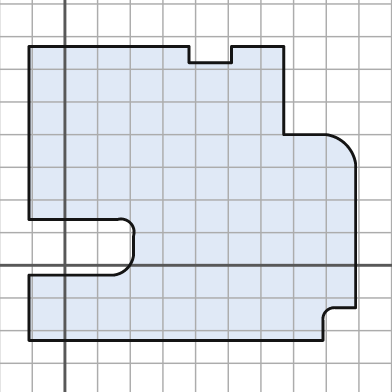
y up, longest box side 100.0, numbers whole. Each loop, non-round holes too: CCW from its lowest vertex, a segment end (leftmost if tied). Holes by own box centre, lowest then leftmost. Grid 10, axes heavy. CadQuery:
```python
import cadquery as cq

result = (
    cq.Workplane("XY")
    .moveTo(-11.0, -23.0)
    .lineTo(79.0, -23.0)
    .lineTo(79.0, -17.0)
    .threePointArc((80.0, -14.0), (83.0, -13.0))
    .lineTo(89.0, -13.0)
    .lineTo(89.0, 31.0)
    .threePointArc((86.0, 37.0), (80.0, 40.0))
    .lineTo(67.0, 40.0)
    .lineTo(67.0, 67.0)
    .lineTo(51.0, 67.0)
    .lineTo(51.0, 62.0)
    .lineTo(38.0, 62.0)
    .lineTo(38.0, 67.0)
    .lineTo(-11.0, 67.0)
    .lineTo(-11.0, 14.0)
    .lineTo(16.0, 14.0)
    .threePointArc((20.0, 13.0), (21.0, 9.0))
    .lineTo(21.0, 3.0)
    .threePointArc((19.0, -1.0), (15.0, -3.0))
    .lineTo(-11.0, -3.0)
    .close()
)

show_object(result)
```